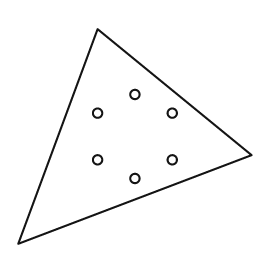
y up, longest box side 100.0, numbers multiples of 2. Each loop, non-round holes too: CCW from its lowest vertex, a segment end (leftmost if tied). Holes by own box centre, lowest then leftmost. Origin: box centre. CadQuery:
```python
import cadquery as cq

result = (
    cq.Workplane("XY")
    .moveTo(-50.0, -46.0)
    .lineTo(50.0, -8.0)
    .lineTo(-16.0, 46.0)
    .close()
    .moveTo(0.0, -18.0)
    .circle(2.0)
    .moveTo(-16.0, -10.0)
    .circle(2.0)
    .moveTo(16.0, -10.0)
    .circle(2.0)
    .moveTo(-16.0, 10.0)
    .circle(2.0)
    .moveTo(16.0, 10.0)
    .circle(2.0)
    .moveTo(0.0, 18.0)
    .circle(2.0)
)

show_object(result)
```